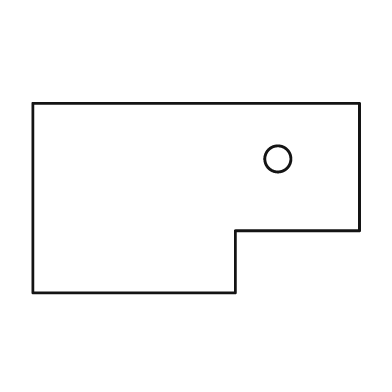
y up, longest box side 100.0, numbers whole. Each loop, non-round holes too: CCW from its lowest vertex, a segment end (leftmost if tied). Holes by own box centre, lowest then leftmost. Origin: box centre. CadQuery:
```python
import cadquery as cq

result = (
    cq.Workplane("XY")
    .moveTo(-50.0, -29.0)
    .lineTo(12.0, -29.0)
    .lineTo(12.0, -10.0)
    .lineTo(50.0, -10.0)
    .lineTo(50.0, 29.0)
    .lineTo(-50.0, 29.0)
    .close()
    .moveTo(25.0, 12.0)
    .circle(4.0)
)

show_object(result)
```